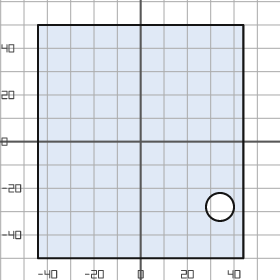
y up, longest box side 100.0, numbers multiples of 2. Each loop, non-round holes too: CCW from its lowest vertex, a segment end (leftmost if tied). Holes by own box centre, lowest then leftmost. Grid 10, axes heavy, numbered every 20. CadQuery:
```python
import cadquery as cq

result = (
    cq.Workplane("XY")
    .moveTo(-44.0, -50.0)
    .lineTo(44.0, -50.0)
    .lineTo(44.0, 50.0)
    .lineTo(-44.0, 50.0)
    .close()
    .moveTo(34.0, -28.0)
    .circle(6.0)
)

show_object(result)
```